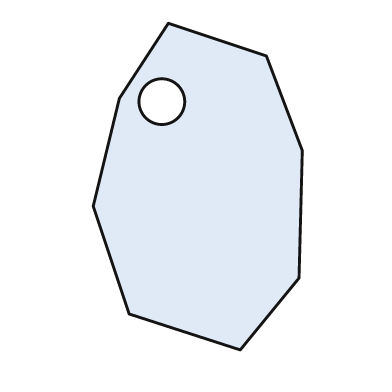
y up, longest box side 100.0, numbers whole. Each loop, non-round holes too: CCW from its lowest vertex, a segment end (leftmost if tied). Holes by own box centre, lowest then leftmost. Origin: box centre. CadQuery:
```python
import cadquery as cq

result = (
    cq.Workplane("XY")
    .moveTo(13.0, -50.0)
    .lineTo(31.0, -28.0)
    .lineTo(32.0, 11.0)
    .lineTo(21.0, 40.0)
    .lineTo(-9.0, 50.0)
    .lineTo(-24.0, 27.0)
    .lineTo(-32.0, -6.0)
    .lineTo(-21.0, -39.0)
    .close()
    .moveTo(-11.0, 26.0)
    .circle(7.0)
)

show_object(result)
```